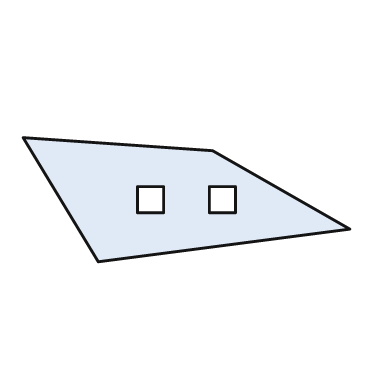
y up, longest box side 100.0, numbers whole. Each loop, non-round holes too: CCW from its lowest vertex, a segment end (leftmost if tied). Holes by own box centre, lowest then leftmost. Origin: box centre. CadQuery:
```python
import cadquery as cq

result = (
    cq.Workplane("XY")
    .moveTo(-27.0, -19.0)
    .lineTo(50.0, -9.0)
    .lineTo(8.0, 15.0)
    .lineTo(-50.0, 19.0)
    .close()
    .moveTo(-15.0, -4.0)
    .lineTo(-7.0, -4.0)
    .lineTo(-7.0, 4.0)
    .lineTo(-15.0, 4.0)
    .close()
    .moveTo(7.0, -4.0)
    .lineTo(15.0, -4.0)
    .lineTo(15.0, 4.0)
    .lineTo(7.0, 4.0)
    .close()
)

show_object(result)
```